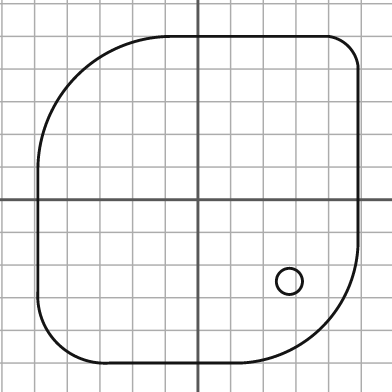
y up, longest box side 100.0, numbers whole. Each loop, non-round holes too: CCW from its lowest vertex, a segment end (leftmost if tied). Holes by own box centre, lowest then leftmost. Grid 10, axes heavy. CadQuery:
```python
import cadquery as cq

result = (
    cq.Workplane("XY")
    .moveTo(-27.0, -50.0)
    .lineTo(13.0, -50.0)
    .threePointArc((38.0, -39.0), (49.0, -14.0))
    .lineTo(49.0, 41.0)
    .threePointArc((46.0, 47.0), (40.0, 50.0))
    .lineTo(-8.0, 50.0)
    .threePointArc((-37.0, 38.0), (-49.0, 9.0))
    .lineTo(-49.0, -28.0)
    .threePointArc((-43.0, -44.0), (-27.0, -50.0))
    .close()
    .moveTo(28.0, -25.0)
    .circle(4.0)
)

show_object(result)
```